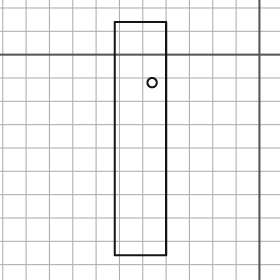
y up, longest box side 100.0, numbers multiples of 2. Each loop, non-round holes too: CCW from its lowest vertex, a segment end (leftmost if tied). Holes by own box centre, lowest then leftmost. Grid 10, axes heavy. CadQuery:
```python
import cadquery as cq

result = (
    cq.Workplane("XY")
    .moveTo(-62.0, -86.0)
    .lineTo(-40.0, -86.0)
    .lineTo(-40.0, 14.0)
    .lineTo(-62.0, 14.0)
    .close()
    .moveTo(-46.0, -12.0)
    .circle(2.0)
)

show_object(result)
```